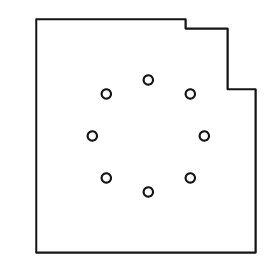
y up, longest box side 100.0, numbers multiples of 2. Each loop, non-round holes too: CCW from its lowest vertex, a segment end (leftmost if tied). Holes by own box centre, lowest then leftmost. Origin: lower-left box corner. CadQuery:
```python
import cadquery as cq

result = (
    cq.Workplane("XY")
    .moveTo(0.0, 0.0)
    .lineTo(94.0, 0.0)
    .lineTo(94.0, 70.0)
    .lineTo(82.0, 70.0)
    .lineTo(82.0, 96.0)
    .lineTo(64.0, 96.0)
    .lineTo(64.0, 100.0)
    .lineTo(0.0, 100.0)
    .close()
    .moveTo(48.0, 26.0)
    .circle(2.0)
    .moveTo(30.0, 32.0)
    .circle(2.0)
    .moveTo(66.0, 32.0)
    .circle(2.0)
    .moveTo(24.0, 50.0)
    .circle(2.0)
    .moveTo(72.0, 50.0)
    .circle(2.0)
    .moveTo(30.0, 68.0)
    .circle(2.0)
    .moveTo(66.0, 68.0)
    .circle(2.0)
    .moveTo(48.0, 74.0)
    .circle(2.0)
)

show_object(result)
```